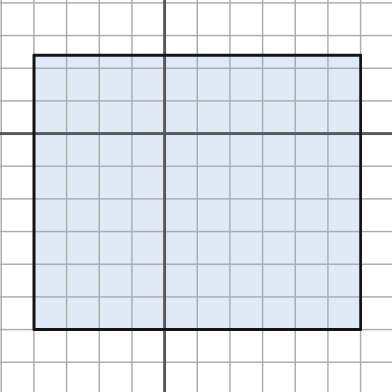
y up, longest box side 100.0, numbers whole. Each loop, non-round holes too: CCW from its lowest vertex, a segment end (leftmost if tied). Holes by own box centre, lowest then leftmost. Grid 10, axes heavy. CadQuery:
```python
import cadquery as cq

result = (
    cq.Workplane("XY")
    .moveTo(-40.0, -60.0)
    .lineTo(60.0, -60.0)
    .lineTo(60.0, 24.0)
    .lineTo(-40.0, 24.0)
    .close()
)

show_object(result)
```